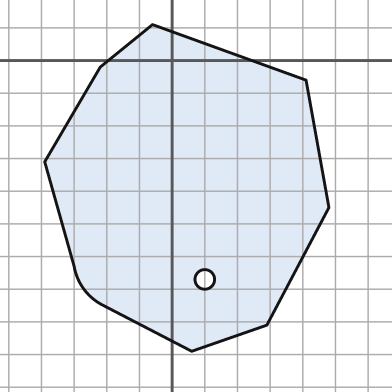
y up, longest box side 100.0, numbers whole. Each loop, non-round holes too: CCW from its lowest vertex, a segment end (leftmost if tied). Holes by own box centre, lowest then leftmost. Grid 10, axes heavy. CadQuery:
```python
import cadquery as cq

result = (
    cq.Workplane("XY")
    .moveTo(6.0, -89.0)
    .lineTo(29.0, -81.0)
    .lineTo(48.0, -45.0)
    .lineTo(41.0, -6.0)
    .lineTo(-6.0, 11.0)
    .lineTo(-22.0, -2.0)
    .lineTo(-39.0, -31.0)
    .lineTo(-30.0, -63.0)
    .threePointArc((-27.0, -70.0), (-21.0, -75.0))
    .close()
    .moveTo(10.0, -67.0)
    .circle(3.0)
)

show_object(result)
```